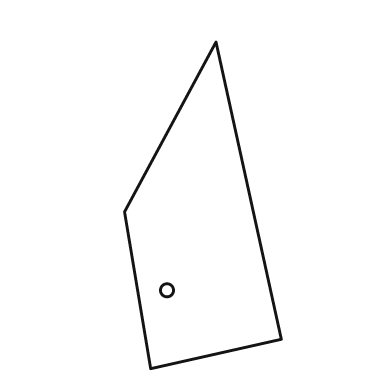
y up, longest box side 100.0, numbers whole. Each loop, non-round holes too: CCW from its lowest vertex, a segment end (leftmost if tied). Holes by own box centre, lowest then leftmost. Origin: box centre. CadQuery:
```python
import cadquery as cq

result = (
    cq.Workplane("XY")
    .moveTo(-16.0, -50.0)
    .lineTo(24.0, -41.0)
    .lineTo(4.0, 50.0)
    .lineTo(-24.0, -2.0)
    .close()
    .moveTo(-11.0, -26.0)
    .circle(2.0)
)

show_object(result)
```